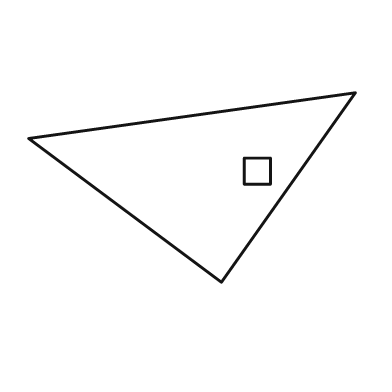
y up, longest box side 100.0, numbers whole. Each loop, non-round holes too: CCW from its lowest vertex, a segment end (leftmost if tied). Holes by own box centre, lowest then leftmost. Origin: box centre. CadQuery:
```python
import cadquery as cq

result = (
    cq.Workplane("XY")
    .moveTo(9.0, -29.0)
    .lineTo(50.0, 29.0)
    .lineTo(-50.0, 15.0)
    .close()
    .moveTo(16.0, 1.0)
    .lineTo(24.0, 1.0)
    .lineTo(24.0, 9.0)
    .lineTo(16.0, 9.0)
    .close()
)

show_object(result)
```